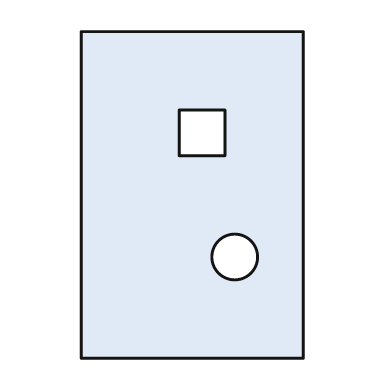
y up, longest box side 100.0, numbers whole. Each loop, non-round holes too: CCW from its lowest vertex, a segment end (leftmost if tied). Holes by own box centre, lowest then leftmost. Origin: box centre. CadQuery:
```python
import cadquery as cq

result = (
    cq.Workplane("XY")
    .moveTo(-34.0, -50.0)
    .lineTo(34.0, -50.0)
    .lineTo(34.0, 50.0)
    .lineTo(-34.0, 50.0)
    .close()
    .moveTo(13.0, -19.0)
    .circle(7.0)
    .moveTo(-4.0, 12.0)
    .lineTo(10.0, 12.0)
    .lineTo(10.0, 26.0)
    .lineTo(-4.0, 26.0)
    .close()
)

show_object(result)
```